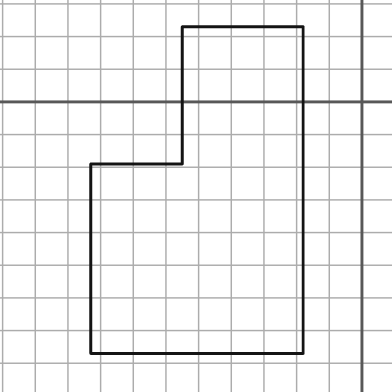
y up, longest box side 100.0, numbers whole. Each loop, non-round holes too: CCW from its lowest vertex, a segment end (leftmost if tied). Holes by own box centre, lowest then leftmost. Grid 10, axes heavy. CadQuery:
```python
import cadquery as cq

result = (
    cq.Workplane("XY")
    .moveTo(-83.0, -77.0)
    .lineTo(-18.0, -77.0)
    .lineTo(-18.0, 23.0)
    .lineTo(-55.0, 23.0)
    .lineTo(-55.0, -19.0)
    .lineTo(-83.0, -19.0)
    .close()
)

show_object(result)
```